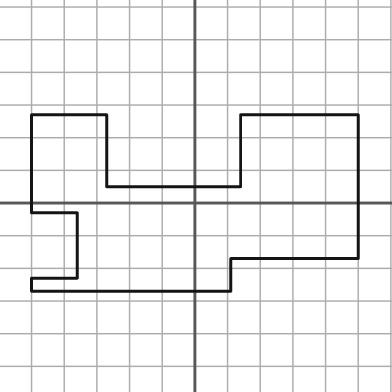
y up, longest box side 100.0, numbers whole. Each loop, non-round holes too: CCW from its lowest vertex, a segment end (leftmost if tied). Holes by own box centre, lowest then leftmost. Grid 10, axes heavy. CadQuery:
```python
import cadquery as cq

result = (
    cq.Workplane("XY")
    .moveTo(-50.0, -27.0)
    .lineTo(11.0, -27.0)
    .lineTo(11.0, -17.0)
    .lineTo(50.0, -17.0)
    .lineTo(50.0, 27.0)
    .lineTo(14.0, 27.0)
    .lineTo(14.0, 5.0)
    .lineTo(-27.0, 5.0)
    .lineTo(-27.0, 27.0)
    .lineTo(-50.0, 27.0)
    .lineTo(-50.0, -3.0)
    .lineTo(-36.0, -3.0)
    .lineTo(-36.0, -23.0)
    .lineTo(-50.0, -23.0)
    .close()
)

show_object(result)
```